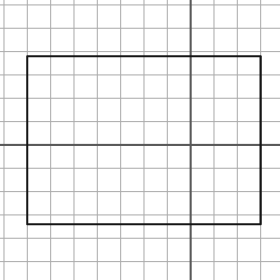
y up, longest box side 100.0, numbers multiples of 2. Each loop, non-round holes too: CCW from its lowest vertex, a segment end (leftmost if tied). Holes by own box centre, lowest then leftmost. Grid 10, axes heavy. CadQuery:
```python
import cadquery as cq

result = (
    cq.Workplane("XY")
    .moveTo(-70.0, -34.0)
    .lineTo(30.0, -34.0)
    .lineTo(30.0, 38.0)
    .lineTo(-70.0, 38.0)
    .close()
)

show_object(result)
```